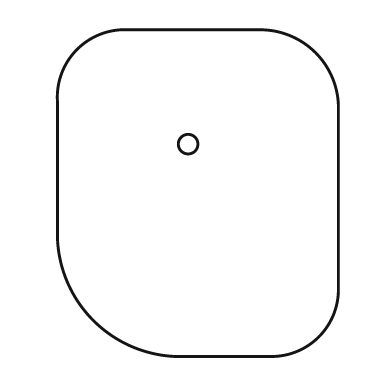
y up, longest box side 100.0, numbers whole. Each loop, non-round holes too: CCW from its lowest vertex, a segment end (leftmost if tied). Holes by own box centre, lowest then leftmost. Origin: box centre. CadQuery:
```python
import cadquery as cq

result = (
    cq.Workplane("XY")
    .moveTo(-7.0, -50.0)
    .lineTo(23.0, -50.0)
    .threePointArc((37.0, -44.0), (43.0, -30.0))
    .lineTo(43.0, 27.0)
    .threePointArc((36.0, 43.0), (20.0, 50.0))
    .lineTo(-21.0, 50.0)
    .threePointArc((-37.0, 44.0), (-43.0, 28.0))
    .lineTo(-43.0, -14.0)
    .threePointArc((-32.0, -39.0), (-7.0, -50.0))
    .close()
    .moveTo(-3.0, 15.0)
    .circle(3.0)
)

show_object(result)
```